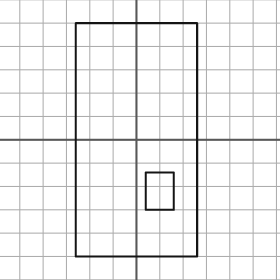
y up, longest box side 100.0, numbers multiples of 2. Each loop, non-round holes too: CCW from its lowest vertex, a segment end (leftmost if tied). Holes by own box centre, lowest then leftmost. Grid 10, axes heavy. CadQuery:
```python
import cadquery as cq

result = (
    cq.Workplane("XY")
    .moveTo(-26.0, -50.0)
    .lineTo(26.0, -50.0)
    .lineTo(26.0, 50.0)
    .lineTo(-26.0, 50.0)
    .close()
    .moveTo(4.0, -30.0)
    .lineTo(16.0, -30.0)
    .lineTo(16.0, -14.0)
    .lineTo(4.0, -14.0)
    .close()
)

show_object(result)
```